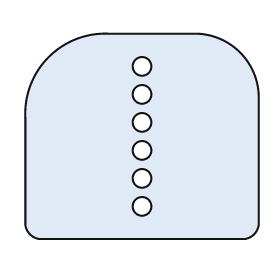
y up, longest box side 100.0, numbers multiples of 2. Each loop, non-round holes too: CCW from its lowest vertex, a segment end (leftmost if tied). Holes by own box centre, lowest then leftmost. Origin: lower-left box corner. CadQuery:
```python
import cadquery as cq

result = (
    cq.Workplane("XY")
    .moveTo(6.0, 0.0)
    .lineTo(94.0, 0.0)
    .threePointArc((98.0, 2.0), (100.0, 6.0))
    .lineTo(100.0, 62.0)
    .threePointArc((92.0, 80.0), (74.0, 88.0))
    .lineTo(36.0, 88.0)
    .threePointArc((10.0, 78.0), (0.0, 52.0))
    .lineTo(0.0, 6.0)
    .threePointArc((2.0, 2.0), (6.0, 0.0))
    .close()
    .moveTo(50.0, 14.0)
    .circle(4.0)
    .moveTo(50.0, 26.0)
    .circle(4.0)
    .moveTo(50.0, 38.0)
    .circle(4.0)
    .moveTo(50.0, 50.0)
    .circle(4.0)
    .moveTo(50.0, 62.0)
    .circle(4.0)
    .moveTo(50.0, 74.0)
    .circle(4.0)
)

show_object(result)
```